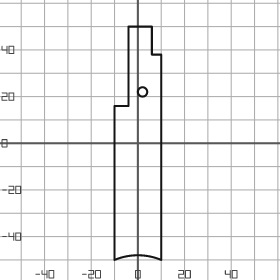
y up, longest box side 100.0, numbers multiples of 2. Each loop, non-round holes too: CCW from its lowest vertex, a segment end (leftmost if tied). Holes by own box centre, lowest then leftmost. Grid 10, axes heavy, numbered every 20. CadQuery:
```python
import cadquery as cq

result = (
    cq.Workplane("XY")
    .moveTo(-10.0, -50.0)
    .threePointArc((0.0, -48.0), (10.0, -50.0))
    .lineTo(10.0, 38.0)
    .lineTo(6.0, 38.0)
    .lineTo(6.0, 50.0)
    .lineTo(-4.0, 50.0)
    .lineTo(-4.0, 16.0)
    .lineTo(-10.0, 16.0)
    .close()
    .moveTo(2.0, 22.0)
    .circle(2.0)
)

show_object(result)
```